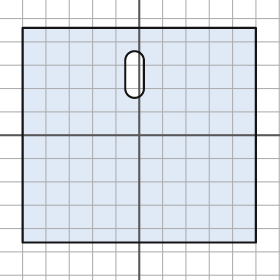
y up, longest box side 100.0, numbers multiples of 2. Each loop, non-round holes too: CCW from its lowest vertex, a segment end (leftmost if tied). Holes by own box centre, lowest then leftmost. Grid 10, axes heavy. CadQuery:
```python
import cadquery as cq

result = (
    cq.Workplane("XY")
    .moveTo(-50.0, -46.0)
    .lineTo(50.0, -46.0)
    .lineTo(50.0, 46.0)
    .lineTo(-50.0, 46.0)
    .close()
    .moveTo(-6.0, 20.0)
    .threePointArc((-2.0, 16.0), (2.0, 20.0))
    .lineTo(2.0, 32.0)
    .threePointArc((-2.0, 36.0), (-6.0, 32.0))
    .close()
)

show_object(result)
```